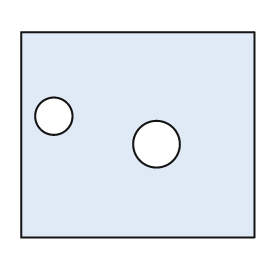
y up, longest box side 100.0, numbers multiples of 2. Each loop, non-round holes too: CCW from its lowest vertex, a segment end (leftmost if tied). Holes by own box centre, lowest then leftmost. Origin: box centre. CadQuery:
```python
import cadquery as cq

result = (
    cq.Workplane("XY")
    .moveTo(-50.0, -44.0)
    .lineTo(50.0, -44.0)
    .lineTo(50.0, 44.0)
    .lineTo(-50.0, 44.0)
    .close()
    .moveTo(8.0, -4.0)
    .circle(10.0)
    .moveTo(-36.0, 8.0)
    .circle(8.0)
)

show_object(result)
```